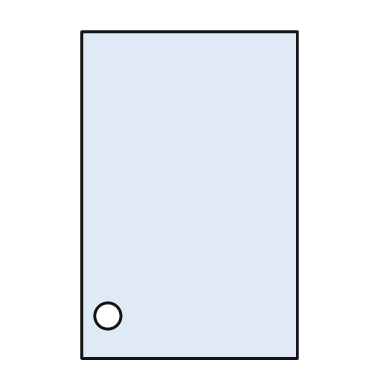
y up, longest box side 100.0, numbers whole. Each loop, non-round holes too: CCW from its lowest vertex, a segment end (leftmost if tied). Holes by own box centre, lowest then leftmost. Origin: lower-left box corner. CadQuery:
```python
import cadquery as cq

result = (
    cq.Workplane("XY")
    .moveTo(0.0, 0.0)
    .lineTo(66.0, 0.0)
    .lineTo(66.0, 100.0)
    .lineTo(0.0, 100.0)
    .close()
    .moveTo(8.0, 13.0)
    .circle(4.0)
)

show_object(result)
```